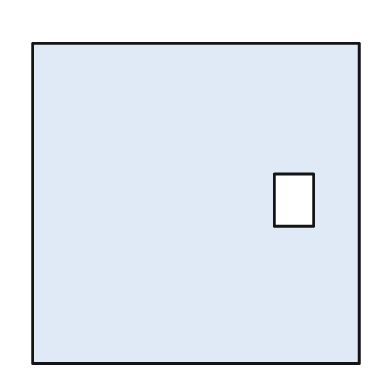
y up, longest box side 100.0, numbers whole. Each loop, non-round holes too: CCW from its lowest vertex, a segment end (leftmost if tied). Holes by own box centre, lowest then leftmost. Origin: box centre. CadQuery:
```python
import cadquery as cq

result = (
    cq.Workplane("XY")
    .moveTo(-50.0, -49.0)
    .lineTo(50.0, -49.0)
    .lineTo(50.0, 49.0)
    .lineTo(-50.0, 49.0)
    .close()
    .moveTo(24.0, -7.0)
    .lineTo(36.0, -7.0)
    .lineTo(36.0, 9.0)
    .lineTo(24.0, 9.0)
    .close()
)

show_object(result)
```